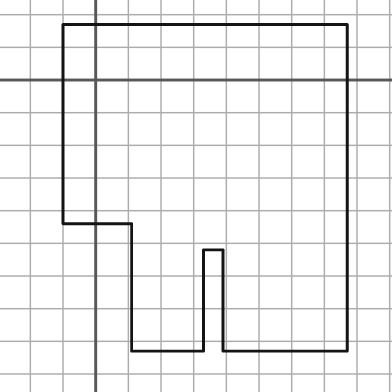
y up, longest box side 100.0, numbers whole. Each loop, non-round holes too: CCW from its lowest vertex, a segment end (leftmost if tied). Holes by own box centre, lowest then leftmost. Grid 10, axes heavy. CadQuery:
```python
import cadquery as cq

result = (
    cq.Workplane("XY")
    .moveTo(11.0, -83.0)
    .lineTo(33.0, -83.0)
    .lineTo(33.0, -52.0)
    .lineTo(39.0, -52.0)
    .lineTo(39.0, -83.0)
    .lineTo(77.0, -83.0)
    .lineTo(77.0, 17.0)
    .lineTo(-10.0, 17.0)
    .lineTo(-10.0, -44.0)
    .lineTo(11.0, -44.0)
    .close()
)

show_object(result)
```